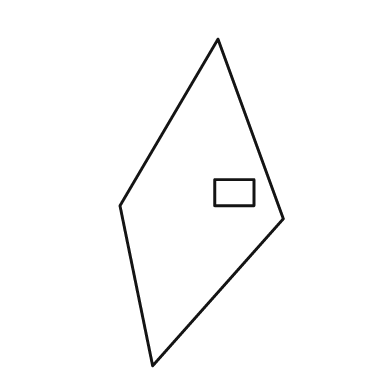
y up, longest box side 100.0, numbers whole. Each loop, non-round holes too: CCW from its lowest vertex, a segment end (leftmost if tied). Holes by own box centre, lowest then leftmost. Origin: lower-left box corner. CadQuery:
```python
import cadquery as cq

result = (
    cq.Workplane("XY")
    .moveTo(10.0, 0.0)
    .lineTo(50.0, 45.0)
    .lineTo(30.0, 100.0)
    .lineTo(0.0, 49.0)
    .close()
    .moveTo(29.0, 49.0)
    .lineTo(41.0, 49.0)
    .lineTo(41.0, 57.0)
    .lineTo(29.0, 57.0)
    .close()
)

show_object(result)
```